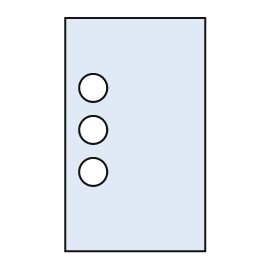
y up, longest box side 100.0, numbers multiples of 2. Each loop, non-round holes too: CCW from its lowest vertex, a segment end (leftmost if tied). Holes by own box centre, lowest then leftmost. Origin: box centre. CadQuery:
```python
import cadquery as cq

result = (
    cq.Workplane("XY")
    .moveTo(-30.0, -50.0)
    .lineTo(30.0, -50.0)
    .lineTo(30.0, 50.0)
    .lineTo(-30.0, 50.0)
    .close()
    .moveTo(-18.0, -16.0)
    .circle(6.0)
    .moveTo(-18.0, 2.0)
    .circle(6.0)
    .moveTo(-18.0, 20.0)
    .circle(6.0)
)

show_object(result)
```